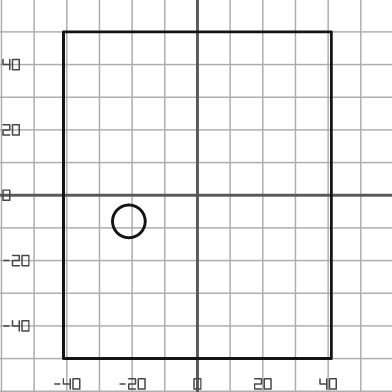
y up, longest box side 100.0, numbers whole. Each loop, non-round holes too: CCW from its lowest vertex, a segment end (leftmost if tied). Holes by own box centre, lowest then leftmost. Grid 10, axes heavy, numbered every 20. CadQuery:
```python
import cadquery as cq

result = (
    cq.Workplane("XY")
    .moveTo(-41.0, -50.0)
    .lineTo(41.0, -50.0)
    .lineTo(41.0, 50.0)
    .lineTo(-41.0, 50.0)
    .close()
    .moveTo(-21.0, -8.0)
    .circle(5.0)
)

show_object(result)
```